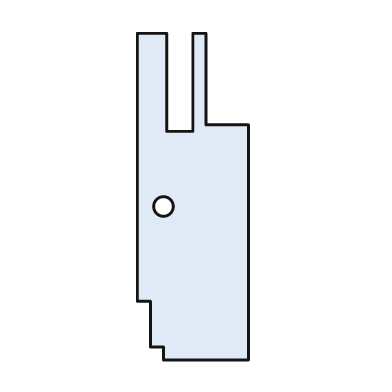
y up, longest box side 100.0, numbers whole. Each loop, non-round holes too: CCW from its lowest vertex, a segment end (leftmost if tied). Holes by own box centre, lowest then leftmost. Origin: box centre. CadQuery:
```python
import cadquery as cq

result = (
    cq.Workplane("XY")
    .moveTo(-9.0, -50.0)
    .lineTo(17.0, -50.0)
    .lineTo(17.0, 22.0)
    .lineTo(4.0, 22.0)
    .lineTo(4.0, 50.0)
    .lineTo(0.0, 50.0)
    .lineTo(0.0, 20.0)
    .lineTo(-8.0, 20.0)
    .lineTo(-8.0, 50.0)
    .lineTo(-17.0, 50.0)
    .lineTo(-17.0, -32.0)
    .lineTo(-13.0, -32.0)
    .lineTo(-13.0, -46.0)
    .lineTo(-9.0, -46.0)
    .close()
    .moveTo(-9.0, -3.0)
    .circle(3.0)
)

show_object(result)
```